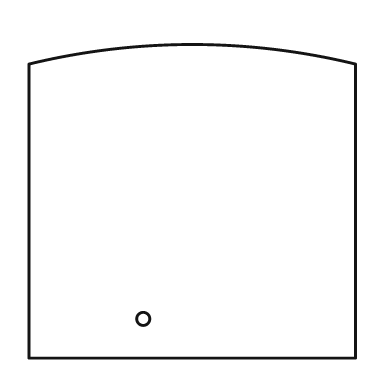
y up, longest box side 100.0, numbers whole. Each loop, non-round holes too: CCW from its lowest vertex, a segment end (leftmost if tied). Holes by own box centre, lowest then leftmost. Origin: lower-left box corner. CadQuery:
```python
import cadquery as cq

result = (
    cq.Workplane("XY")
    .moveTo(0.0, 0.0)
    .lineTo(100.0, 0.0)
    .lineTo(100.0, 90.0)
    .threePointArc((50.0, 96.0), (0.0, 90.0))
    .close()
    .moveTo(35.0, 12.0)
    .circle(2.0)
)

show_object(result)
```